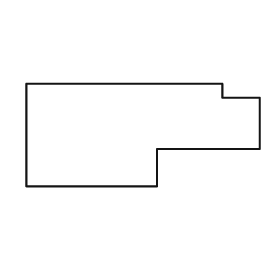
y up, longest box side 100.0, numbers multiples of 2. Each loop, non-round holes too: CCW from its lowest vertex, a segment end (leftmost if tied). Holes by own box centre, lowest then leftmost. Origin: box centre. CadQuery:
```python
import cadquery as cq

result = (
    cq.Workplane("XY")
    .moveTo(-50.0, -22.0)
    .lineTo(6.0, -22.0)
    .lineTo(6.0, -6.0)
    .lineTo(50.0, -6.0)
    .lineTo(50.0, 16.0)
    .lineTo(34.0, 16.0)
    .lineTo(34.0, 22.0)
    .lineTo(-50.0, 22.0)
    .close()
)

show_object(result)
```